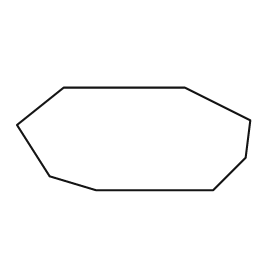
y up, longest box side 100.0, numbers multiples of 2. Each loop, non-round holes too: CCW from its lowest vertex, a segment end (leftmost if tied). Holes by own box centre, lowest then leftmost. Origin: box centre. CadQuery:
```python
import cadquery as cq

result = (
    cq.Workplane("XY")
    .moveTo(-16.0, -22.0)
    .lineTo(34.0, -22.0)
    .lineTo(48.0, -8.0)
    .lineTo(50.0, 8.0)
    .lineTo(22.0, 22.0)
    .lineTo(-30.0, 22.0)
    .lineTo(-50.0, 6.0)
    .lineTo(-36.0, -16.0)
    .close()
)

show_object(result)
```